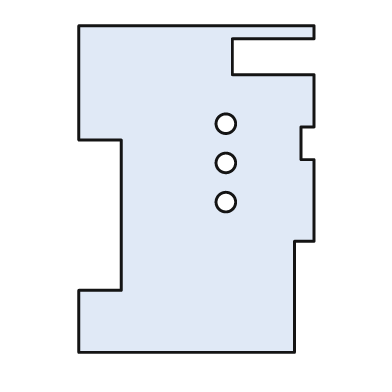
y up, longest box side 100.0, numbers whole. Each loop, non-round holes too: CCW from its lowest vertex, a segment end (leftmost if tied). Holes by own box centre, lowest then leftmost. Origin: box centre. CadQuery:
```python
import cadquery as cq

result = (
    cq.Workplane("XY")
    .moveTo(-36.0, -50.0)
    .lineTo(30.0, -50.0)
    .lineTo(30.0, -16.0)
    .lineTo(36.0, -16.0)
    .lineTo(36.0, 9.0)
    .lineTo(32.0, 9.0)
    .lineTo(32.0, 19.0)
    .lineTo(36.0, 19.0)
    .lineTo(36.0, 35.0)
    .lineTo(11.0, 35.0)
    .lineTo(11.0, 46.0)
    .lineTo(36.0, 46.0)
    .lineTo(36.0, 50.0)
    .lineTo(-36.0, 50.0)
    .lineTo(-36.0, 15.0)
    .lineTo(-23.0, 15.0)
    .lineTo(-23.0, -31.0)
    .lineTo(-36.0, -31.0)
    .close()
    .moveTo(9.0, -4.0)
    .circle(3.0)
    .moveTo(9.0, 8.0)
    .circle(3.0)
    .moveTo(9.0, 20.0)
    .circle(3.0)
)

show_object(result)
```